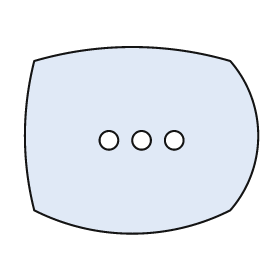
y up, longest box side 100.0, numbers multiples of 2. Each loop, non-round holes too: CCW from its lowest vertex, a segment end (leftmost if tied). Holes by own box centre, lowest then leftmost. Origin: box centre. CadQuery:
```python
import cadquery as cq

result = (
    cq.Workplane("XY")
    .moveTo(-46.0, -30.0)
    .threePointArc((-4.0, -40.0), (38.0, -30.0))
    .threePointArc((50.0, 2.0), (38.0, 34.0))
    .threePointArc((-4.0, 40.0), (-46.0, 34.0))
    .threePointArc((-50.0, 2.0), (-46.0, -30.0))
    .close()
    .moveTo(-14.0, 0.0)
    .circle(4.0)
    .moveTo(0.0, 0.0)
    .circle(4.0)
    .moveTo(14.0, 0.0)
    .circle(4.0)
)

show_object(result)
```